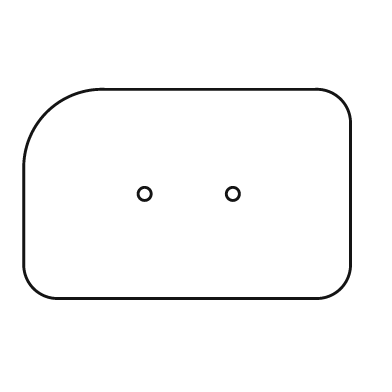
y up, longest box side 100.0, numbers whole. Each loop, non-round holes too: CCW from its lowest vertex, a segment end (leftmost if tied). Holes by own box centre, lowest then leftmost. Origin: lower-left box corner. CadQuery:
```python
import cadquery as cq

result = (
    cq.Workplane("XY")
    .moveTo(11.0, 0.0)
    .lineTo(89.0, 0.0)
    .threePointArc((97.0, 3.0), (100.0, 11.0))
    .lineTo(100.0, 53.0)
    .threePointArc((97.0, 61.0), (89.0, 64.0))
    .lineTo(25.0, 64.0)
    .threePointArc((7.0, 57.0), (0.0, 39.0))
    .lineTo(0.0, 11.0)
    .threePointArc((3.0, 3.0), (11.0, 0.0))
    .close()
    .moveTo(37.0, 32.0)
    .circle(2.0)
    .moveTo(64.0, 32.0)
    .circle(2.0)
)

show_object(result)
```